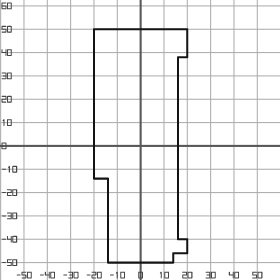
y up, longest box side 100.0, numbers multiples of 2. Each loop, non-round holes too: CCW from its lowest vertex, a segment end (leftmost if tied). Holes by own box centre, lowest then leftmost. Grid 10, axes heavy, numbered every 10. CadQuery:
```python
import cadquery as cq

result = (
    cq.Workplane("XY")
    .moveTo(-14.0, -50.0)
    .lineTo(14.0, -50.0)
    .lineTo(14.0, -46.0)
    .lineTo(20.0, -46.0)
    .lineTo(20.0, -40.0)
    .lineTo(16.0, -40.0)
    .lineTo(16.0, 38.0)
    .lineTo(20.0, 38.0)
    .lineTo(20.0, 50.0)
    .lineTo(-20.0, 50.0)
    .lineTo(-20.0, -14.0)
    .lineTo(-14.0, -14.0)
    .close()
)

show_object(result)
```